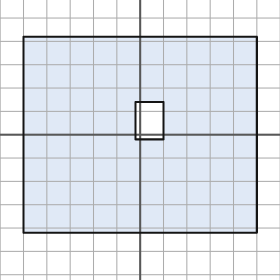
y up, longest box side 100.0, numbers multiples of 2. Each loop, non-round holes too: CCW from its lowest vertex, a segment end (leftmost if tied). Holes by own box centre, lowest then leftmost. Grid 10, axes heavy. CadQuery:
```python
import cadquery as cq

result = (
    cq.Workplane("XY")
    .moveTo(-50.0, -42.0)
    .lineTo(50.0, -42.0)
    .lineTo(50.0, 42.0)
    .lineTo(-50.0, 42.0)
    .close()
    .moveTo(-2.0, -2.0)
    .lineTo(10.0, -2.0)
    .lineTo(10.0, 14.0)
    .lineTo(-2.0, 14.0)
    .close()
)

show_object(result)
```